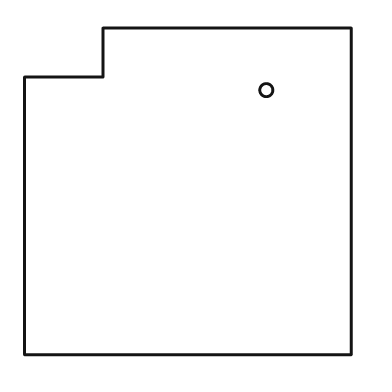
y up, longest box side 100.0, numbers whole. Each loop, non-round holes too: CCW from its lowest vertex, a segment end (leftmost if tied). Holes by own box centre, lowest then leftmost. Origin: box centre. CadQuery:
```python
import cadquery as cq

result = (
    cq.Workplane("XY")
    .moveTo(-50.0, -50.0)
    .lineTo(50.0, -50.0)
    .lineTo(50.0, 50.0)
    .lineTo(-26.0, 50.0)
    .lineTo(-26.0, 35.0)
    .lineTo(-50.0, 35.0)
    .close()
    .moveTo(24.0, 31.0)
    .circle(2.0)
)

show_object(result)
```